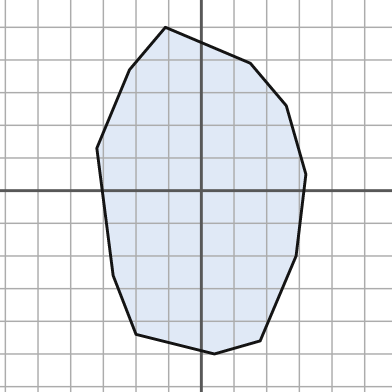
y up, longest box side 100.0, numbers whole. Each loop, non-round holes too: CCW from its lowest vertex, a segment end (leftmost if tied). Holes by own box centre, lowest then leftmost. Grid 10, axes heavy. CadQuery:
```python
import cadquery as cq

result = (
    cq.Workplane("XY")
    .moveTo(4.0, -50.0)
    .lineTo(18.0, -46.0)
    .lineTo(29.0, -20.0)
    .lineTo(32.0, 5.0)
    .lineTo(26.0, 26.0)
    .lineTo(15.0, 39.0)
    .lineTo(-11.0, 50.0)
    .lineTo(-22.0, 37.0)
    .lineTo(-32.0, 13.0)
    .lineTo(-27.0, -26.0)
    .lineTo(-20.0, -44.0)
    .close()
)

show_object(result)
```